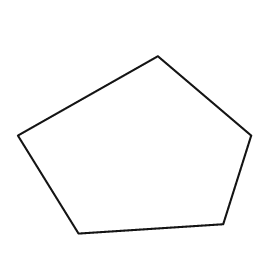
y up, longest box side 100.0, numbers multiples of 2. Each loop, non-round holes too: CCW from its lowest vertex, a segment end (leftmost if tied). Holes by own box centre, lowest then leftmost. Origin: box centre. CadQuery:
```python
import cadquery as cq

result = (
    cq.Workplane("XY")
    .moveTo(-24.0, -38.0)
    .lineTo(38.0, -34.0)
    .lineTo(50.0, 4.0)
    .lineTo(10.0, 38.0)
    .lineTo(-50.0, 4.0)
    .close()
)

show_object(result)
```